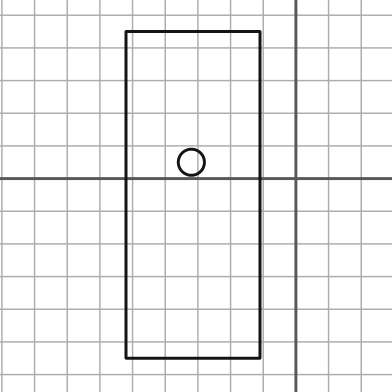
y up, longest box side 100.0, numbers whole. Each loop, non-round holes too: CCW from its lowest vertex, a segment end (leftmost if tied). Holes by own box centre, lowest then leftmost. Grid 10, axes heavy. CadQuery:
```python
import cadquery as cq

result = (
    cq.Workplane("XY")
    .moveTo(-52.0, -55.0)
    .lineTo(-11.0, -55.0)
    .lineTo(-11.0, 45.0)
    .lineTo(-52.0, 45.0)
    .close()
    .moveTo(-32.0, 5.0)
    .circle(4.0)
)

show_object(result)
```